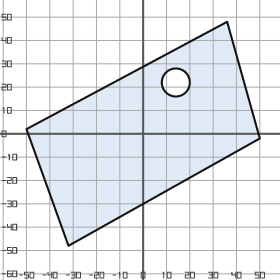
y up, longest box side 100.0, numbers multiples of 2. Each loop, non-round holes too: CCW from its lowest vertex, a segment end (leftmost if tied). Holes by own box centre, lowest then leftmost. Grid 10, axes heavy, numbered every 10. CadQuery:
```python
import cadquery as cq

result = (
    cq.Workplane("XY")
    .moveTo(-32.0, -48.0)
    .lineTo(50.0, -2.0)
    .lineTo(36.0, 48.0)
    .lineTo(-50.0, 2.0)
    .close()
    .moveTo(14.0, 22.0)
    .circle(6.0)
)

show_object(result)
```